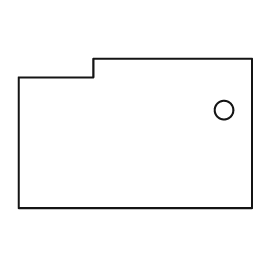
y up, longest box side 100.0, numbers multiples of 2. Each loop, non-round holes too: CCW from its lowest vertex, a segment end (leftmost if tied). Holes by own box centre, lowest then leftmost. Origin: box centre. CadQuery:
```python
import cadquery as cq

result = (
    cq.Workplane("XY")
    .moveTo(-50.0, -32.0)
    .lineTo(50.0, -32.0)
    .lineTo(50.0, 32.0)
    .lineTo(-18.0, 32.0)
    .lineTo(-18.0, 24.0)
    .lineTo(-50.0, 24.0)
    .close()
    .moveTo(38.0, 10.0)
    .circle(4.0)
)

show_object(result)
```